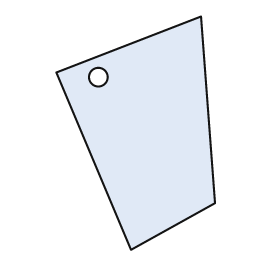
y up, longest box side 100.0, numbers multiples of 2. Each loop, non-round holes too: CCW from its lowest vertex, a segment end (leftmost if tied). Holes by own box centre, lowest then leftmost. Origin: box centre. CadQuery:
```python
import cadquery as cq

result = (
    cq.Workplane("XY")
    .moveTo(-2.0, -50.0)
    .lineTo(34.0, -30.0)
    .lineTo(28.0, 50.0)
    .lineTo(-34.0, 26.0)
    .close()
    .moveTo(-16.0, 24.0)
    .circle(4.0)
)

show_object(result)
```